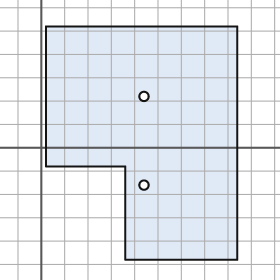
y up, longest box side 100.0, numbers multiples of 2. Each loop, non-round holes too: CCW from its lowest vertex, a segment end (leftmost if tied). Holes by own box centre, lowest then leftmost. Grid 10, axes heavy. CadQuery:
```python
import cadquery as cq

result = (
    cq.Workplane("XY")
    .moveTo(36.0, -48.0)
    .lineTo(84.0, -48.0)
    .lineTo(84.0, 52.0)
    .lineTo(2.0, 52.0)
    .lineTo(2.0, -8.0)
    .lineTo(36.0, -8.0)
    .close()
    .moveTo(44.0, -16.0)
    .circle(2.0)
    .moveTo(44.0, 22.0)
    .circle(2.0)
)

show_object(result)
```